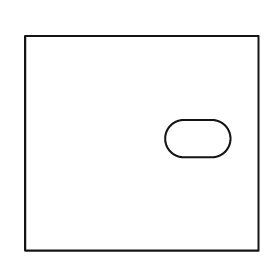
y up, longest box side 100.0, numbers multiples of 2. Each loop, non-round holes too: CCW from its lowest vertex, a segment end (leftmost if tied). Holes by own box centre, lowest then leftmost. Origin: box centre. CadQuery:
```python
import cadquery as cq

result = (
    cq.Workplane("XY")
    .moveTo(-50.0, -46.0)
    .lineTo(50.0, -46.0)
    .lineTo(50.0, 46.0)
    .lineTo(-50.0, 46.0)
    .close()
    .moveTo(18.0, -6.0)
    .lineTo(30.0, -6.0)
    .threePointArc((38.0, 2.0), (30.0, 10.0))
    .lineTo(18.0, 10.0)
    .threePointArc((10.0, 2.0), (18.0, -6.0))
    .close()
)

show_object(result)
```